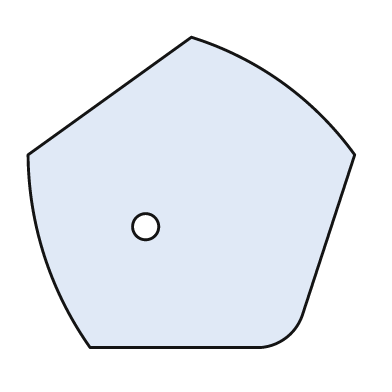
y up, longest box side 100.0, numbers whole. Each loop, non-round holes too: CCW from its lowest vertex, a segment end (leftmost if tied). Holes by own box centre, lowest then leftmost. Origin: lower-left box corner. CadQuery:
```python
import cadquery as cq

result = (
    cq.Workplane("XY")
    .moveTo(19.0, 0.0)
    .lineTo(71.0, 0.0)
    .threePointArc((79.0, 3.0), (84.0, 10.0))
    .lineTo(100.0, 59.0)
    .threePointArc((78.0, 81.0), (50.0, 95.0))
    .lineTo(0.0, 59.0)
    .threePointArc((5.0, 28.0), (19.0, 0.0))
    .close()
    .moveTo(36.0, 37.0)
    .circle(4.0)
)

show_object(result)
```